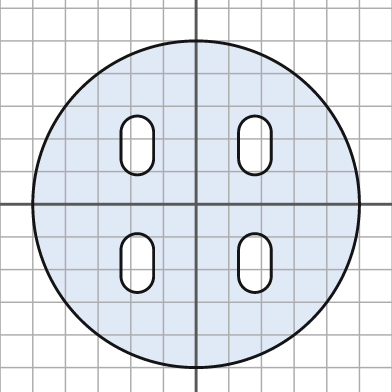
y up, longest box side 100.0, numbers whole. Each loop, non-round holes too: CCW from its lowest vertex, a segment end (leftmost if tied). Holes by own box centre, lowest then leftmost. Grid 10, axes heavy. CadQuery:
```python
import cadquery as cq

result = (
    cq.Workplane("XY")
    .moveTo(0.0, 0.0)
    .circle(50.0)
    .moveTo(-23.0, -22.0)
    .threePointArc((-18.0, -27.0), (-13.0, -22.0))
    .lineTo(-13.0, -14.0)
    .threePointArc((-18.0, -9.0), (-23.0, -14.0))
    .close()
    .moveTo(13.0, -22.0)
    .threePointArc((18.0, -27.0), (23.0, -22.0))
    .lineTo(23.0, -14.0)
    .threePointArc((18.0, -9.0), (13.0, -14.0))
    .close()
    .moveTo(-23.0, 14.0)
    .threePointArc((-18.0, 9.0), (-13.0, 14.0))
    .lineTo(-13.0, 22.0)
    .threePointArc((-18.0, 27.0), (-23.0, 22.0))
    .close()
    .moveTo(13.0, 14.0)
    .threePointArc((18.0, 9.0), (23.0, 14.0))
    .lineTo(23.0, 22.0)
    .threePointArc((18.0, 27.0), (13.0, 22.0))
    .close()
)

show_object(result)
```